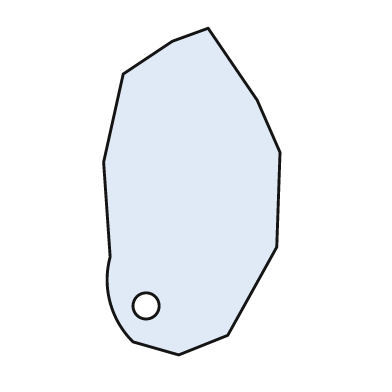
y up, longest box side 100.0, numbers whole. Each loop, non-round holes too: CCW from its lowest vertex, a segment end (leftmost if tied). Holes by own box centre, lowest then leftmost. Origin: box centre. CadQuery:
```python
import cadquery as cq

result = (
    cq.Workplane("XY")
    .moveTo(-4.0, -50.0)
    .lineTo(11.0, -44.0)
    .lineTo(26.0, -17.0)
    .lineTo(27.0, 12.0)
    .lineTo(20.0, 28.0)
    .lineTo(5.0, 50.0)
    .lineTo(-6.0, 46.0)
    .lineTo(-21.0, 36.0)
    .lineTo(-27.0, 9.0)
    .lineTo(-25.0, -20.0)
    .threePointArc((-25.0, -34.0), (-18.0, -46.0))
    .close()
    .moveTo(-14.0, -35.0)
    .circle(4.0)
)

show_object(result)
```